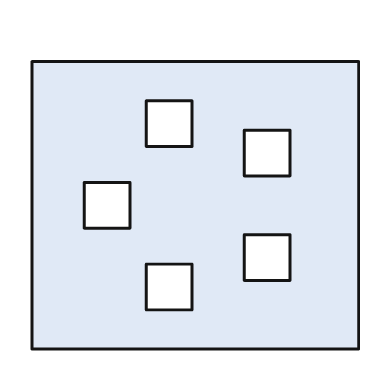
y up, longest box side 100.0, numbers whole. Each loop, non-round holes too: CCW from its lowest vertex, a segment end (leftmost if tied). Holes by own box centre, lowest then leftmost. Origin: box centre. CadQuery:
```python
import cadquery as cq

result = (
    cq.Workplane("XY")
    .moveTo(-50.0, -44.0)
    .lineTo(50.0, -44.0)
    .lineTo(50.0, 44.0)
    .lineTo(-50.0, 44.0)
    .close()
    .moveTo(-15.0, -32.0)
    .lineTo(-1.0, -32.0)
    .lineTo(-1.0, -18.0)
    .lineTo(-15.0, -18.0)
    .close()
    .moveTo(15.0, -23.0)
    .lineTo(29.0, -23.0)
    .lineTo(29.0, -9.0)
    .lineTo(15.0, -9.0)
    .close()
    .moveTo(-34.0, -7.0)
    .lineTo(-20.0, -7.0)
    .lineTo(-20.0, 7.0)
    .lineTo(-34.0, 7.0)
    .close()
    .moveTo(15.0, 9.0)
    .lineTo(29.0, 9.0)
    .lineTo(29.0, 23.0)
    .lineTo(15.0, 23.0)
    .close()
    .moveTo(-15.0, 18.0)
    .lineTo(-1.0, 18.0)
    .lineTo(-1.0, 32.0)
    .lineTo(-15.0, 32.0)
    .close()
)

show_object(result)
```